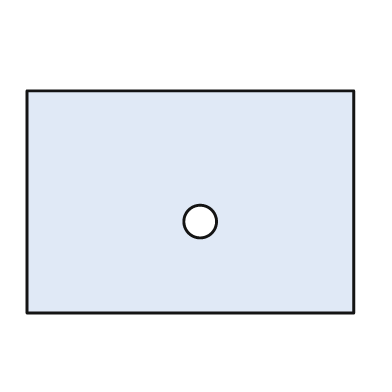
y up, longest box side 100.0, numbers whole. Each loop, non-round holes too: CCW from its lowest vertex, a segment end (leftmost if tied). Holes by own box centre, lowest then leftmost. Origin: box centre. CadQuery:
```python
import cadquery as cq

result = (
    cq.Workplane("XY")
    .moveTo(-50.0, -34.0)
    .lineTo(50.0, -34.0)
    .lineTo(50.0, 34.0)
    .lineTo(-50.0, 34.0)
    .close()
    .moveTo(3.0, -6.0)
    .circle(5.0)
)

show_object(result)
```